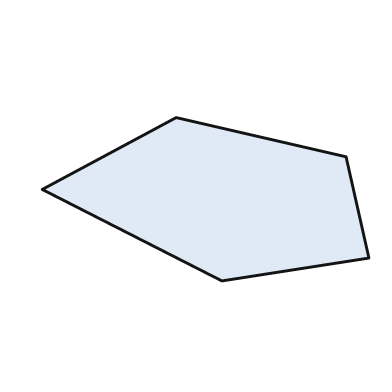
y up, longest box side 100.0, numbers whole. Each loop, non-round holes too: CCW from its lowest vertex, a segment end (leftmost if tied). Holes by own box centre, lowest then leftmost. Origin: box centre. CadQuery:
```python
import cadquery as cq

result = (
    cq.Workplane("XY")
    .moveTo(5.0, -25.0)
    .lineTo(50.0, -18.0)
    .lineTo(43.0, 13.0)
    .lineTo(-9.0, 25.0)
    .lineTo(-50.0, 3.0)
    .close()
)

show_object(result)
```